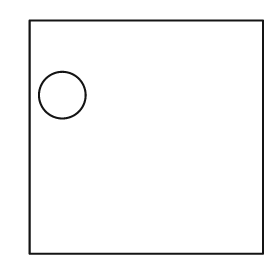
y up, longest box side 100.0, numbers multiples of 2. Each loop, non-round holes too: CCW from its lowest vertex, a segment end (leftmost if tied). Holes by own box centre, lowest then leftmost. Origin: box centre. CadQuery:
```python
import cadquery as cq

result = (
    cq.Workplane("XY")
    .moveTo(-50.0, -50.0)
    .lineTo(50.0, -50.0)
    .lineTo(50.0, 50.0)
    .lineTo(-50.0, 50.0)
    .close()
    .moveTo(-36.0, 18.0)
    .circle(10.0)
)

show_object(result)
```